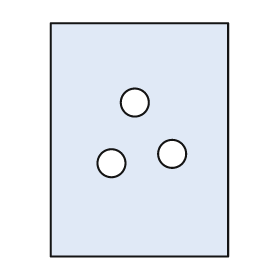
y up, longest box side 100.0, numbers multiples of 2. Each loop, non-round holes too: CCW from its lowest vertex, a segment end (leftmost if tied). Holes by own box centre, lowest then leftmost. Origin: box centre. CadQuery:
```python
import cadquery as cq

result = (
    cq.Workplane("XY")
    .moveTo(-38.0, -50.0)
    .lineTo(38.0, -50.0)
    .lineTo(38.0, 50.0)
    .lineTo(-38.0, 50.0)
    .close()
    .moveTo(-12.0, -10.0)
    .circle(6.0)
    .moveTo(14.0, -6.0)
    .circle(6.0)
    .moveTo(-2.0, 16.0)
    .circle(6.0)
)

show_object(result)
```